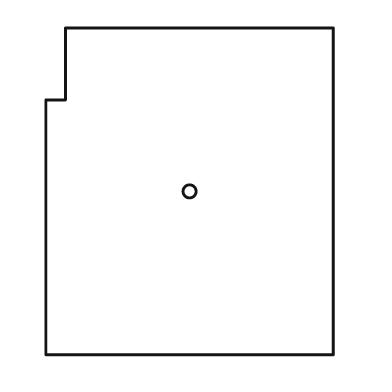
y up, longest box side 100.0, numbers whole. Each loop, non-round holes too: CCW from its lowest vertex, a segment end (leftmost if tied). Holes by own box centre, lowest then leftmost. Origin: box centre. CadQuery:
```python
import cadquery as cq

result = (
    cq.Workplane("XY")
    .moveTo(-44.0, -50.0)
    .lineTo(44.0, -50.0)
    .lineTo(44.0, 50.0)
    .lineTo(-38.0, 50.0)
    .lineTo(-38.0, 28.0)
    .lineTo(-44.0, 28.0)
    .close()
    .moveTo(0.0, 0.0)
    .circle(2.0)
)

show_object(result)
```